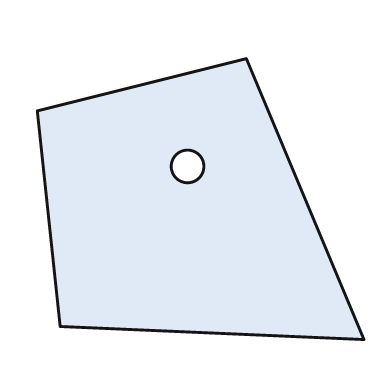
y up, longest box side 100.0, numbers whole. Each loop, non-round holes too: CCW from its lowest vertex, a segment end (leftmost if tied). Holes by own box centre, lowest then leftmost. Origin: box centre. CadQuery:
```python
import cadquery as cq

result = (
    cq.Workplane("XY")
    .moveTo(50.0, -43.0)
    .lineTo(14.0, 43.0)
    .lineTo(-50.0, 27.0)
    .lineTo(-43.0, -39.0)
    .close()
    .moveTo(-4.0, 10.0)
    .circle(5.0)
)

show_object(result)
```